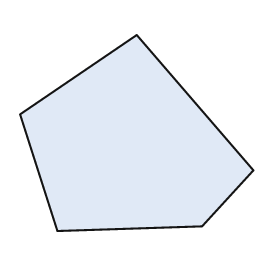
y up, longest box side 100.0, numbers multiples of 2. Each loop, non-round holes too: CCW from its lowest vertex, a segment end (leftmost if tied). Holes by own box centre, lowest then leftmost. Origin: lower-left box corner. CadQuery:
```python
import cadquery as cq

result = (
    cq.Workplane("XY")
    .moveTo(16.0, 0.0)
    .lineTo(78.0, 2.0)
    .lineTo(100.0, 26.0)
    .lineTo(50.0, 84.0)
    .lineTo(0.0, 50.0)
    .close()
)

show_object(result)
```